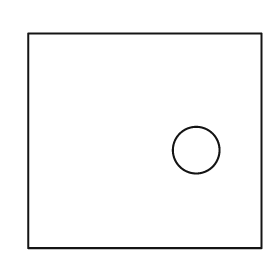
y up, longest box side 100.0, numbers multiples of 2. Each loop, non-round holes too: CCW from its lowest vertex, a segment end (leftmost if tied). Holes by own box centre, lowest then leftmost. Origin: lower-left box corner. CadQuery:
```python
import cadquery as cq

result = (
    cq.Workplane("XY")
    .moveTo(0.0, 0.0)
    .lineTo(100.0, 0.0)
    .lineTo(100.0, 92.0)
    .lineTo(0.0, 92.0)
    .close()
    .moveTo(72.0, 42.0)
    .circle(10.0)
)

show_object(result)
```